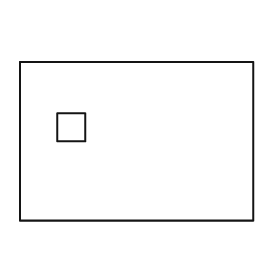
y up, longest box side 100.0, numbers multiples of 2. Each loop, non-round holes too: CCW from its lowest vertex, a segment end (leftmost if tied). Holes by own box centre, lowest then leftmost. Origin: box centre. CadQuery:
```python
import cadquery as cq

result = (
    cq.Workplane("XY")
    .moveTo(-50.0, -34.0)
    .lineTo(50.0, -34.0)
    .lineTo(50.0, 34.0)
    .lineTo(-50.0, 34.0)
    .close()
    .moveTo(-34.0, 0.0)
    .lineTo(-22.0, 0.0)
    .lineTo(-22.0, 12.0)
    .lineTo(-34.0, 12.0)
    .close()
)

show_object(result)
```